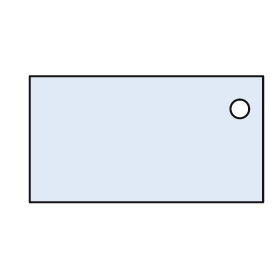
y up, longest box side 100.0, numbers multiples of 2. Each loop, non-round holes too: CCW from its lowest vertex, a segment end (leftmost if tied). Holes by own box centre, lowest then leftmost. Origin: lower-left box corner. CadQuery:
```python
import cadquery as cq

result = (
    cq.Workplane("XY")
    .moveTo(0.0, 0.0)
    .lineTo(100.0, 0.0)
    .lineTo(100.0, 54.0)
    .lineTo(0.0, 54.0)
    .close()
    .moveTo(90.0, 40.0)
    .circle(4.0)
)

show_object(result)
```